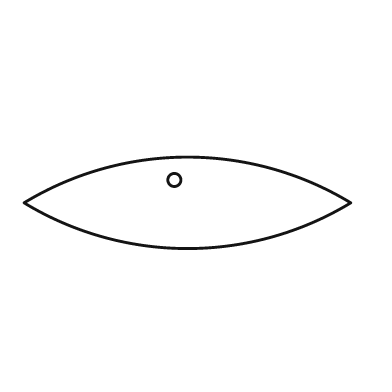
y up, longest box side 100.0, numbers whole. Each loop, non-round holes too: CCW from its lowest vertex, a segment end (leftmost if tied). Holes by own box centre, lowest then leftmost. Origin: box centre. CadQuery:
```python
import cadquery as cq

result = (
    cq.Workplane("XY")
    .moveTo(-50.0, 0.0)
    .threePointArc((0.0, -14.0), (50.0, 0.0))
    .threePointArc((0.0, 14.0), (-50.0, 0.0))
    .close()
    .moveTo(-4.0, 7.0)
    .circle(2.0)
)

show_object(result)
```